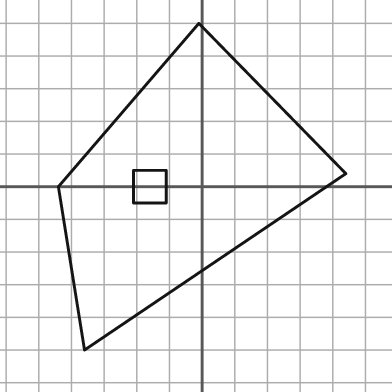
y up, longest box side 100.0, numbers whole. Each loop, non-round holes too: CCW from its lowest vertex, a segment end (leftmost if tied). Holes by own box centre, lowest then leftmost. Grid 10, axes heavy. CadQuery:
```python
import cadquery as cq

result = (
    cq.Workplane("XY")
    .moveTo(-36.0, -50.0)
    .lineTo(44.0, 4.0)
    .lineTo(-1.0, 50.0)
    .lineTo(-44.0, 0.0)
    .close()
    .moveTo(-21.0, -5.0)
    .lineTo(-11.0, -5.0)
    .lineTo(-11.0, 5.0)
    .lineTo(-21.0, 5.0)
    .close()
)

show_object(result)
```